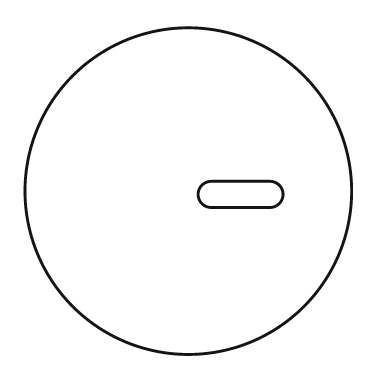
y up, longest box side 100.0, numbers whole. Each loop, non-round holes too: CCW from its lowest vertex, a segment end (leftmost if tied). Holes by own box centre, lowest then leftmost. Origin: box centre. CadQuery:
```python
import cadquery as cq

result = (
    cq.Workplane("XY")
    .moveTo(0.0, 0.0)
    .circle(50.0)
    .moveTo(7.0, -5.0)
    .lineTo(25.0, -5.0)
    .threePointArc((29.0, -1.0), (25.0, 3.0))
    .lineTo(7.0, 3.0)
    .threePointArc((3.0, -1.0), (7.0, -5.0))
    .close()
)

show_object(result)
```